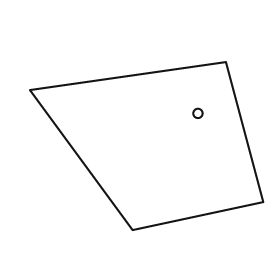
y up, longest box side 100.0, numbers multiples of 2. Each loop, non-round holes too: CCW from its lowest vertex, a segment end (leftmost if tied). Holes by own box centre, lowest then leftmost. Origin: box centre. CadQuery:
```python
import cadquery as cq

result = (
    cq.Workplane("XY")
    .moveTo(-6.0, -36.0)
    .lineTo(50.0, -24.0)
    .lineTo(34.0, 36.0)
    .lineTo(-50.0, 24.0)
    .close()
    .moveTo(22.0, 14.0)
    .circle(2.0)
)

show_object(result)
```